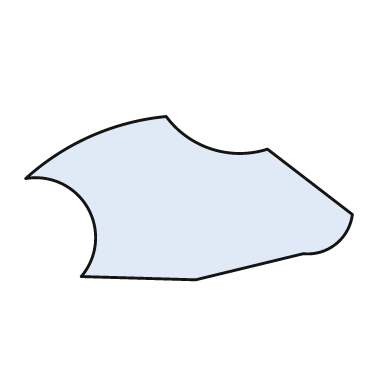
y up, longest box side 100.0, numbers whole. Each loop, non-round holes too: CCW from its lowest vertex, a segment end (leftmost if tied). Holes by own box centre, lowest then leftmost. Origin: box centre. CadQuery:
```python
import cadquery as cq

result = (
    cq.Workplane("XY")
    .moveTo(2.0, -25.0)
    .lineTo(35.0, -17.0)
    .threePointArc((45.0, -14.0), (50.0, -5.0))
    .lineTo(24.0, 15.0)
    .threePointArc((7.0, 15.0), (-7.0, 25.0))
    .threePointArc((-30.0, 19.0), (-50.0, 6.0))
    .threePointArc((-31.0, -3.0), (-33.0, -24.0))
    .close()
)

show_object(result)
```